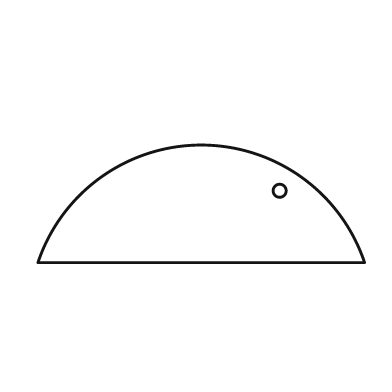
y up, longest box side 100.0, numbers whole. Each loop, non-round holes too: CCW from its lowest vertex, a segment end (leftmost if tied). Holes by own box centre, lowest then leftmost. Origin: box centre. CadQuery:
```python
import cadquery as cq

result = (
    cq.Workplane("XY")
    .moveTo(-50.0, -18.0)
    .lineTo(50.0, -18.0)
    .threePointArc((0.0, 18.0), (-50.0, -18.0))
    .close()
    .moveTo(24.0, 4.0)
    .circle(2.0)
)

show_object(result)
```